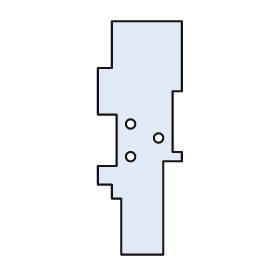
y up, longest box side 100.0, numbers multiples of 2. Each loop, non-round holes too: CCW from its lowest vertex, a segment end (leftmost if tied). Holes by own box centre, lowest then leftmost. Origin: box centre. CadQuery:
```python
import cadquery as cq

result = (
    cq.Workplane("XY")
    .moveTo(-8.0, -50.0)
    .lineTo(10.0, -50.0)
    .lineTo(10.0, -10.0)
    .lineTo(18.0, -10.0)
    .lineTo(18.0, -6.0)
    .lineTo(14.0, -6.0)
    .lineTo(14.0, 20.0)
    .lineTo(18.0, 20.0)
    .lineTo(18.0, 50.0)
    .lineTo(-12.0, 50.0)
    .lineTo(-12.0, 30.0)
    .lineTo(-18.0, 30.0)
    .lineTo(-18.0, 10.0)
    .lineTo(-10.0, 10.0)
    .lineTo(-10.0, -12.0)
    .lineTo(-18.0, -12.0)
    .lineTo(-18.0, -20.0)
    .lineTo(-12.0, -20.0)
    .lineTo(-12.0, -26.0)
    .lineTo(-8.0, -26.0)
    .close()
    .moveTo(-4.0, -8.0)
    .circle(2.0)
    .moveTo(8.0, 0.0)
    .circle(2.0)
    .moveTo(-4.0, 6.0)
    .circle(2.0)
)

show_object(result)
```